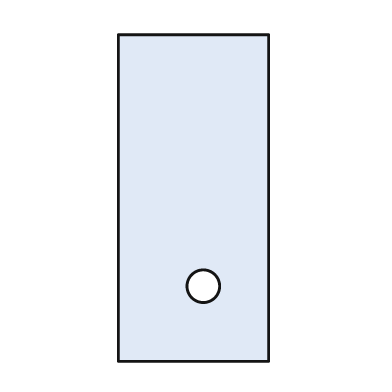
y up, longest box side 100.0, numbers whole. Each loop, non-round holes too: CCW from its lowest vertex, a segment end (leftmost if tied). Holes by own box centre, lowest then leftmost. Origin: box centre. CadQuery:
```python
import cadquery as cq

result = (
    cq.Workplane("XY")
    .moveTo(-23.0, -50.0)
    .lineTo(23.0, -50.0)
    .lineTo(23.0, 50.0)
    .lineTo(-23.0, 50.0)
    .close()
    .moveTo(3.0, -27.0)
    .circle(5.0)
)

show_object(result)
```